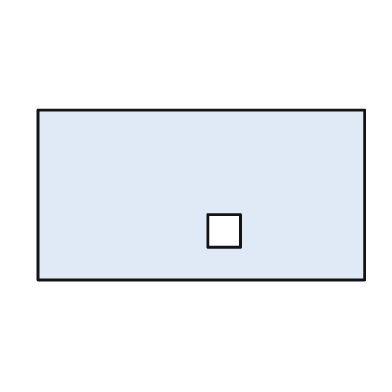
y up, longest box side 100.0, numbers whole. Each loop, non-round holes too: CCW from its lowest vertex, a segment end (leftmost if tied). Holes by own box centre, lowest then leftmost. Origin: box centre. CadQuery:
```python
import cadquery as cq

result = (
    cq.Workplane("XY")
    .moveTo(-50.0, -26.0)
    .lineTo(50.0, -26.0)
    .lineTo(50.0, 26.0)
    .lineTo(-50.0, 26.0)
    .close()
    .moveTo(2.0, -16.0)
    .lineTo(12.0, -16.0)
    .lineTo(12.0, -6.0)
    .lineTo(2.0, -6.0)
    .close()
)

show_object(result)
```